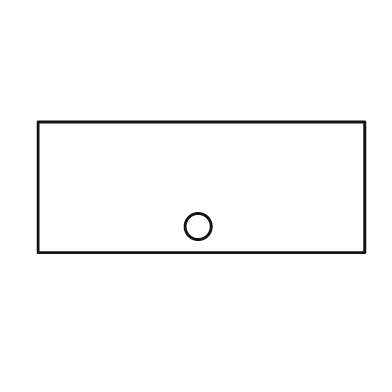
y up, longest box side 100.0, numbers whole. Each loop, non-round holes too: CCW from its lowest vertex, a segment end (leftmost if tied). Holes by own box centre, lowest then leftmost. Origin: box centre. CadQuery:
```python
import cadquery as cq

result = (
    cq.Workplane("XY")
    .moveTo(-50.0, -20.0)
    .lineTo(50.0, -20.0)
    .lineTo(50.0, 20.0)
    .lineTo(-50.0, 20.0)
    .close()
    .moveTo(-1.0, -12.0)
    .circle(4.0)
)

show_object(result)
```